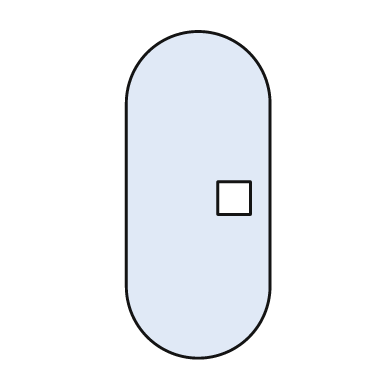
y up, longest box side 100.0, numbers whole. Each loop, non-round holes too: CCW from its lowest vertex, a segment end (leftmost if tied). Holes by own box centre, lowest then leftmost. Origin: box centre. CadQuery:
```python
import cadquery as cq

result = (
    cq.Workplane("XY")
    .moveTo(-22.0, -28.0)
    .threePointArc((0.0, -50.0), (22.0, -28.0))
    .lineTo(22.0, 28.0)
    .threePointArc((0.0, 50.0), (-22.0, 28.0))
    .close()
    .moveTo(6.0, -6.0)
    .lineTo(16.0, -6.0)
    .lineTo(16.0, 4.0)
    .lineTo(6.0, 4.0)
    .close()
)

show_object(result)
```